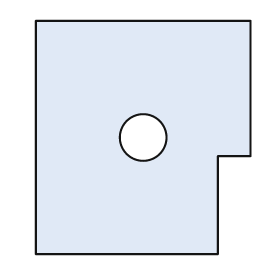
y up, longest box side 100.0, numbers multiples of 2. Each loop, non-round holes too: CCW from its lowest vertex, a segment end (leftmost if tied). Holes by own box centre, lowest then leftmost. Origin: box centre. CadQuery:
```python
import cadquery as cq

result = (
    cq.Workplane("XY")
    .moveTo(-46.0, -50.0)
    .lineTo(32.0, -50.0)
    .lineTo(32.0, -8.0)
    .lineTo(46.0, -8.0)
    .lineTo(46.0, 50.0)
    .lineTo(-46.0, 50.0)
    .close()
    .moveTo(0.0, 0.0)
    .circle(10.0)
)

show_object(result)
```